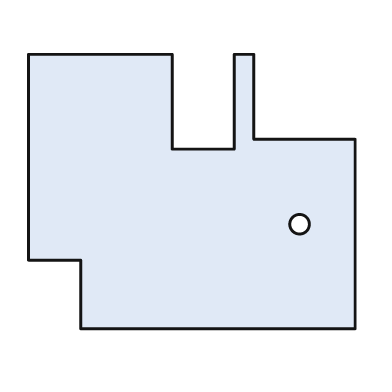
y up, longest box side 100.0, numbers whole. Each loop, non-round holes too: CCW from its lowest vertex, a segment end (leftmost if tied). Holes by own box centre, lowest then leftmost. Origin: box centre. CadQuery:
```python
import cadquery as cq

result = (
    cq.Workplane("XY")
    .moveTo(-34.0, -42.0)
    .lineTo(50.0, -42.0)
    .lineTo(50.0, 16.0)
    .lineTo(19.0, 16.0)
    .lineTo(19.0, 42.0)
    .lineTo(13.0, 42.0)
    .lineTo(13.0, 13.0)
    .lineTo(-6.0, 13.0)
    .lineTo(-6.0, 42.0)
    .lineTo(-50.0, 42.0)
    .lineTo(-50.0, -21.0)
    .lineTo(-34.0, -21.0)
    .close()
    .moveTo(33.0, -10.0)
    .circle(3.0)
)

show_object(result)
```